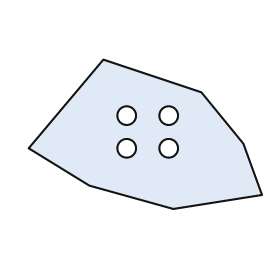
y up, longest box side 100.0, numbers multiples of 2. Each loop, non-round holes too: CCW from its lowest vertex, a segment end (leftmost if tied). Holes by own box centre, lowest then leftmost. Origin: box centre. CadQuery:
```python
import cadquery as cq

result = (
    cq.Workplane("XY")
    .moveTo(12.0, -32.0)
    .lineTo(50.0, -26.0)
    .lineTo(42.0, -4.0)
    .lineTo(24.0, 18.0)
    .lineTo(-18.0, 32.0)
    .lineTo(-50.0, -6.0)
    .lineTo(-24.0, -22.0)
    .close()
    .moveTo(-8.0, -6.0)
    .circle(4.0)
    .moveTo(10.0, -6.0)
    .circle(4.0)
    .moveTo(-8.0, 8.0)
    .circle(4.0)
    .moveTo(10.0, 8.0)
    .circle(4.0)
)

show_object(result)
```